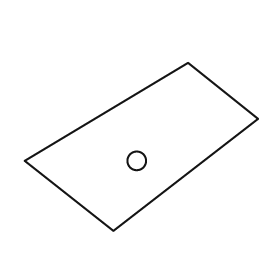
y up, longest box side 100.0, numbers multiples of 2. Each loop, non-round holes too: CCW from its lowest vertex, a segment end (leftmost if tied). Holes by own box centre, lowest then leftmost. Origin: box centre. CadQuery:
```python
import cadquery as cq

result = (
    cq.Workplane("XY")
    .moveTo(-12.0, -36.0)
    .lineTo(50.0, 12.0)
    .lineTo(20.0, 36.0)
    .lineTo(-50.0, -6.0)
    .close()
    .moveTo(-2.0, -6.0)
    .circle(4.0)
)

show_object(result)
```